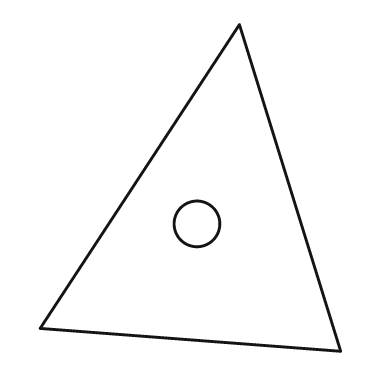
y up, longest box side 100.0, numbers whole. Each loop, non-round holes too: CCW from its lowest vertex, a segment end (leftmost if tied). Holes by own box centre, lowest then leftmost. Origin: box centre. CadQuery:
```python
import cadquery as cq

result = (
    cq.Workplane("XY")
    .moveTo(46.0, -50.0)
    .lineTo(15.0, 50.0)
    .lineTo(-46.0, -43.0)
    .close()
    .moveTo(2.0, -11.0)
    .circle(7.0)
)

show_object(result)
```